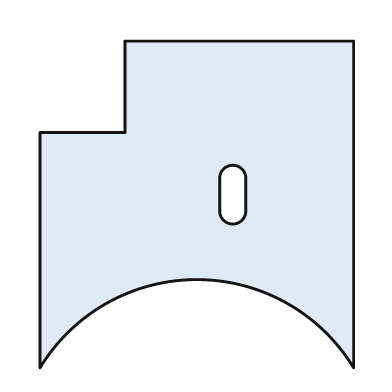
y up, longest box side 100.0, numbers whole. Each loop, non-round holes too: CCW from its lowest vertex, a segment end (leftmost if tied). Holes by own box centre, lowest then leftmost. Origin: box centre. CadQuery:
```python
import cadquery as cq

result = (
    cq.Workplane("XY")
    .moveTo(-48.0, -50.0)
    .threePointArc((0.0, -23.0), (48.0, -50.0))
    .lineTo(48.0, 50.0)
    .lineTo(-22.0, 50.0)
    .lineTo(-22.0, 22.0)
    .lineTo(-48.0, 22.0)
    .close()
    .moveTo(7.0, -2.0)
    .threePointArc((11.0, -6.0), (15.0, -2.0))
    .lineTo(15.0, 8.0)
    .threePointArc((11.0, 12.0), (7.0, 8.0))
    .close()
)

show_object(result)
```